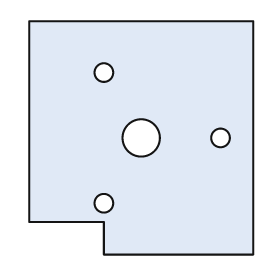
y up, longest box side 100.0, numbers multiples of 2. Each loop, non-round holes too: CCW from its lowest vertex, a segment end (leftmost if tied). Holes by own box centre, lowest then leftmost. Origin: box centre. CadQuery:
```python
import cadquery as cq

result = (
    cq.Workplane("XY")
    .moveTo(-16.0, -50.0)
    .lineTo(48.0, -50.0)
    .lineTo(48.0, 50.0)
    .lineTo(-48.0, 50.0)
    .lineTo(-48.0, -36.0)
    .lineTo(-16.0, -36.0)
    .close()
    .moveTo(-16.0, -28.0)
    .circle(4.0)
    .moveTo(0.0, 0.0)
    .circle(8.0)
    .moveTo(34.0, 0.0)
    .circle(4.0)
    .moveTo(-16.0, 28.0)
    .circle(4.0)
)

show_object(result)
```